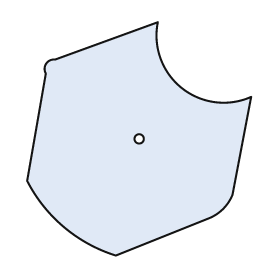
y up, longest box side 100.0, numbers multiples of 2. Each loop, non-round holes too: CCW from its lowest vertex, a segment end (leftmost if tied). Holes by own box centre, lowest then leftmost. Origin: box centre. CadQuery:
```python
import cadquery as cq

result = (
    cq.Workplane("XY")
    .moveTo(-10.0, -50.0)
    .lineTo(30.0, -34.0)
    .threePointArc((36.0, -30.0), (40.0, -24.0))
    .lineTo(48.0, 18.0)
    .threePointArc((18.0, 22.0), (8.0, 50.0))
    .lineTo(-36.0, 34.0)
    .threePointArc((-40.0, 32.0), (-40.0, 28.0))
    .lineTo(-48.0, -18.0)
    .threePointArc((-32.0, -38.0), (-10.0, -50.0))
    .close()
    .moveTo(0.0, 0.0)
    .circle(2.0)
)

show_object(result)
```